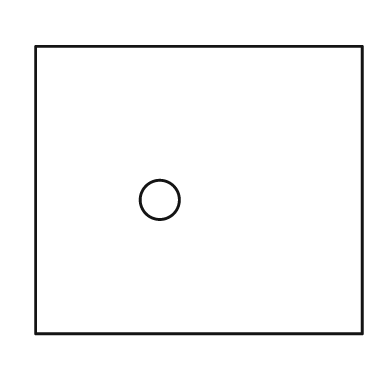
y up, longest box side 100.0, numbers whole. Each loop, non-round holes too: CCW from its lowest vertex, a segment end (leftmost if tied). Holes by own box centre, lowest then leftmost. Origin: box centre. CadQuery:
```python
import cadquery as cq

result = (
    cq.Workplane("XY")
    .moveTo(-50.0, -44.0)
    .lineTo(50.0, -44.0)
    .lineTo(50.0, 44.0)
    .lineTo(-50.0, 44.0)
    .close()
    .moveTo(-12.0, -3.0)
    .circle(6.0)
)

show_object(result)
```